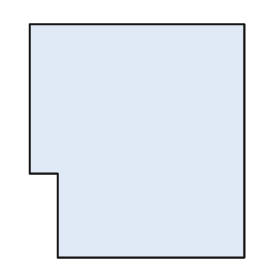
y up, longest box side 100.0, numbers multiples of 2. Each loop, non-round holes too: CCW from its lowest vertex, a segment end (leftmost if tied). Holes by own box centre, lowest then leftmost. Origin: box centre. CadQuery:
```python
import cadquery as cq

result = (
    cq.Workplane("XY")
    .moveTo(-34.0, -50.0)
    .lineTo(46.0, -50.0)
    .lineTo(46.0, 50.0)
    .lineTo(-46.0, 50.0)
    .lineTo(-46.0, -14.0)
    .lineTo(-34.0, -14.0)
    .close()
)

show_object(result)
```